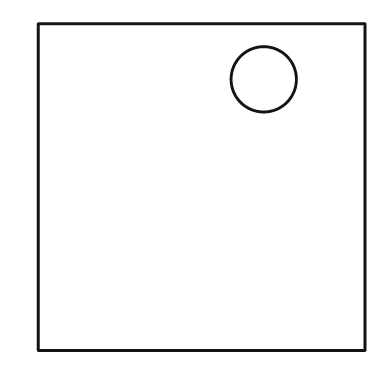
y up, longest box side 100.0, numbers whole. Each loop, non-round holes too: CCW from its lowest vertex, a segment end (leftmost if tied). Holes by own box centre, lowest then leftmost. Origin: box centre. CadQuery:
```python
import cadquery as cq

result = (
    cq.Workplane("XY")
    .moveTo(-50.0, -50.0)
    .lineTo(50.0, -50.0)
    .lineTo(50.0, 50.0)
    .lineTo(-50.0, 50.0)
    .close()
    .moveTo(19.0, 33.0)
    .circle(10.0)
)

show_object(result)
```